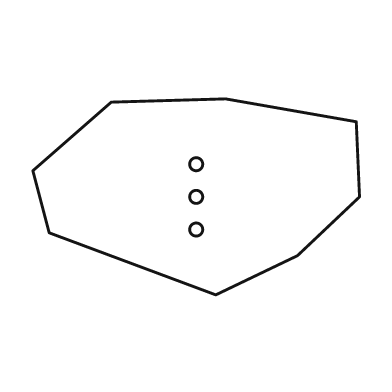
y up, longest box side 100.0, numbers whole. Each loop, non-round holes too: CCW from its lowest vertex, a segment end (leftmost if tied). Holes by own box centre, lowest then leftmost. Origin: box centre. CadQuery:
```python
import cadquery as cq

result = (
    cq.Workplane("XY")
    .moveTo(6.0, -30.0)
    .lineTo(31.0, -18.0)
    .lineTo(50.0, 0.0)
    .lineTo(49.0, 23.0)
    .lineTo(9.0, 30.0)
    .lineTo(-26.0, 29.0)
    .lineTo(-50.0, 8.0)
    .lineTo(-45.0, -11.0)
    .close()
    .moveTo(0.0, -10.0)
    .circle(2.0)
    .moveTo(0.0, 0.0)
    .circle(2.0)
    .moveTo(0.0, 10.0)
    .circle(2.0)
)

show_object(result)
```